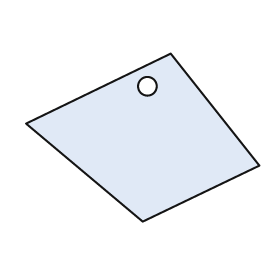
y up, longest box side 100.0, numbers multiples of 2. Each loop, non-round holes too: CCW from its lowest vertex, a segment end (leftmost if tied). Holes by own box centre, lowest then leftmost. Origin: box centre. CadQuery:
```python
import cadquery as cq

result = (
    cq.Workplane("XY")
    .moveTo(0.0, -36.0)
    .lineTo(50.0, -12.0)
    .lineTo(12.0, 36.0)
    .lineTo(-50.0, 6.0)
    .close()
    .moveTo(2.0, 22.0)
    .circle(4.0)
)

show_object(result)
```